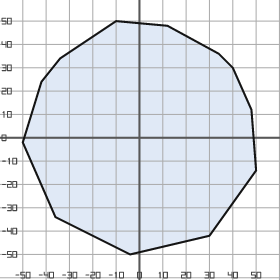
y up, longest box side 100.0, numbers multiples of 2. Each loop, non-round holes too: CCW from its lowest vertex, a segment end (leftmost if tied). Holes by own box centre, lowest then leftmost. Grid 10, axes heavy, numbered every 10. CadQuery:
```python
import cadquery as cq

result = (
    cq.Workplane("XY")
    .moveTo(-4.0, -50.0)
    .lineTo(30.0, -42.0)
    .lineTo(50.0, -14.0)
    .lineTo(48.0, 12.0)
    .lineTo(40.0, 30.0)
    .lineTo(34.0, 36.0)
    .lineTo(12.0, 48.0)
    .lineTo(-10.0, 50.0)
    .lineTo(-34.0, 34.0)
    .lineTo(-42.0, 24.0)
    .lineTo(-50.0, -2.0)
    .lineTo(-36.0, -34.0)
    .close()
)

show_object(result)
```